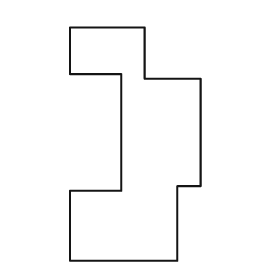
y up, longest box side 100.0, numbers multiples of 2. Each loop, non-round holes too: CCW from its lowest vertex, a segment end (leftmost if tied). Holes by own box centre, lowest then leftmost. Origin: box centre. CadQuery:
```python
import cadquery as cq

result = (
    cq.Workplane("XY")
    .moveTo(-28.0, -50.0)
    .lineTo(18.0, -50.0)
    .lineTo(18.0, -18.0)
    .lineTo(28.0, -18.0)
    .lineTo(28.0, 28.0)
    .lineTo(4.0, 28.0)
    .lineTo(4.0, 50.0)
    .lineTo(-28.0, 50.0)
    .lineTo(-28.0, 30.0)
    .lineTo(-6.0, 30.0)
    .lineTo(-6.0, -20.0)
    .lineTo(-28.0, -20.0)
    .close()
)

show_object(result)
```